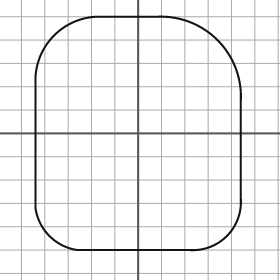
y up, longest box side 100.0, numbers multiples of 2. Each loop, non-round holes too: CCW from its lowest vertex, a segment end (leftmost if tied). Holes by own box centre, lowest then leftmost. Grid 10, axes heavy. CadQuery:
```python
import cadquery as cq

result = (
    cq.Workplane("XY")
    .moveTo(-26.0, -50.0)
    .lineTo(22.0, -50.0)
    .threePointArc((38.0, -44.0), (44.0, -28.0))
    .lineTo(44.0, 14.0)
    .threePointArc((34.0, 40.0), (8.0, 50.0))
    .lineTo(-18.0, 50.0)
    .threePointArc((-36.0, 42.0), (-44.0, 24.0))
    .lineTo(-44.0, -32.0)
    .threePointArc((-38.0, -44.0), (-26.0, -50.0))
    .close()
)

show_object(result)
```